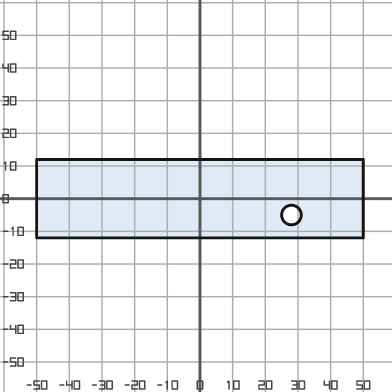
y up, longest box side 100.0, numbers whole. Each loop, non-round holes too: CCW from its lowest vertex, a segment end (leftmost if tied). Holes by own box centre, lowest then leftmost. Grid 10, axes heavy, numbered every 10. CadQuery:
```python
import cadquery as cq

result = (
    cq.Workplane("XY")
    .moveTo(-50.0, -12.0)
    .lineTo(50.0, -12.0)
    .lineTo(50.0, 12.0)
    .lineTo(-50.0, 12.0)
    .close()
    .moveTo(28.0, -5.0)
    .circle(3.0)
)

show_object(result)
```